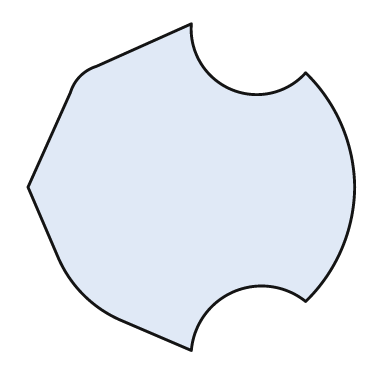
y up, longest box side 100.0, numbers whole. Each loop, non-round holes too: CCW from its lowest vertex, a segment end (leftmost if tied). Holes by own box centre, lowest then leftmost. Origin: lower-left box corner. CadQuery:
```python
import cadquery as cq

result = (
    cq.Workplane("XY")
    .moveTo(50.0, 0.0)
    .threePointArc((63.0, 18.0), (85.0, 15.0))
    .threePointArc((96.0, 31.0), (100.0, 50.0))
    .threePointArc((96.0, 69.0), (85.0, 85.0))
    .threePointArc((62.0, 80.0), (50.0, 100.0))
    .lineTo(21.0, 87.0)
    .threePointArc((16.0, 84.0), (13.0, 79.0))
    .lineTo(0.0, 50.0)
    .lineTo(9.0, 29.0)
    .threePointArc((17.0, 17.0), (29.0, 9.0))
    .close()
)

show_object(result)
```